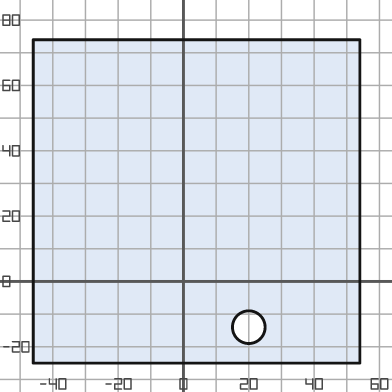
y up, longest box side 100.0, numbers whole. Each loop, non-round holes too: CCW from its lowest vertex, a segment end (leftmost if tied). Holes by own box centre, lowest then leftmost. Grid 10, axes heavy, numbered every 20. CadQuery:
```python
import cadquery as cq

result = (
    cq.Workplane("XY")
    .moveTo(-46.0, -25.0)
    .lineTo(54.0, -25.0)
    .lineTo(54.0, 74.0)
    .lineTo(-46.0, 74.0)
    .close()
    .moveTo(20.0, -14.0)
    .circle(5.0)
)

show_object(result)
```